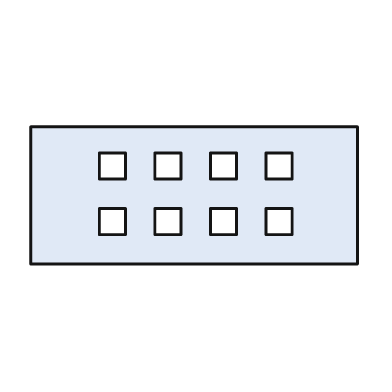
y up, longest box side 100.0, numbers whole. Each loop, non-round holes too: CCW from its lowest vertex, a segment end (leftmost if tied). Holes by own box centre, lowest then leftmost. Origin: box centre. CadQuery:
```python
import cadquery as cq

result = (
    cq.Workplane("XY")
    .moveTo(-50.0, -21.0)
    .lineTo(50.0, -21.0)
    .lineTo(50.0, 21.0)
    .lineTo(-50.0, 21.0)
    .close()
    .moveTo(-29.0, -12.0)
    .lineTo(-21.0, -12.0)
    .lineTo(-21.0, -4.0)
    .lineTo(-29.0, -4.0)
    .close()
    .moveTo(-12.0, -12.0)
    .lineTo(-4.0, -12.0)
    .lineTo(-4.0, -4.0)
    .lineTo(-12.0, -4.0)
    .close()
    .moveTo(5.0, -12.0)
    .lineTo(13.0, -12.0)
    .lineTo(13.0, -4.0)
    .lineTo(5.0, -4.0)
    .close()
    .moveTo(22.0, -12.0)
    .lineTo(30.0, -12.0)
    .lineTo(30.0, -4.0)
    .lineTo(22.0, -4.0)
    .close()
    .moveTo(-29.0, 5.0)
    .lineTo(-21.0, 5.0)
    .lineTo(-21.0, 13.0)
    .lineTo(-29.0, 13.0)
    .close()
    .moveTo(-12.0, 5.0)
    .lineTo(-4.0, 5.0)
    .lineTo(-4.0, 13.0)
    .lineTo(-12.0, 13.0)
    .close()
    .moveTo(5.0, 5.0)
    .lineTo(13.0, 5.0)
    .lineTo(13.0, 13.0)
    .lineTo(5.0, 13.0)
    .close()
    .moveTo(22.0, 5.0)
    .lineTo(30.0, 5.0)
    .lineTo(30.0, 13.0)
    .lineTo(22.0, 13.0)
    .close()
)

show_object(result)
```